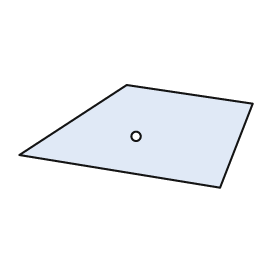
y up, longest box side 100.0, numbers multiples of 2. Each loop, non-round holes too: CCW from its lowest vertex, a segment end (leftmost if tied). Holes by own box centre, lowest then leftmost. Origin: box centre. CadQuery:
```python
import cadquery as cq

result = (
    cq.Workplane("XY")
    .moveTo(36.0, -22.0)
    .lineTo(50.0, 14.0)
    .lineTo(-4.0, 22.0)
    .lineTo(-50.0, -8.0)
    .close()
    .moveTo(0.0, 0.0)
    .circle(2.0)
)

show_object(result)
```